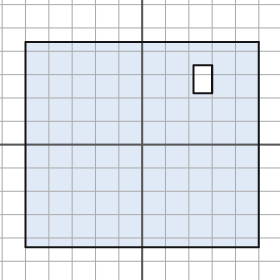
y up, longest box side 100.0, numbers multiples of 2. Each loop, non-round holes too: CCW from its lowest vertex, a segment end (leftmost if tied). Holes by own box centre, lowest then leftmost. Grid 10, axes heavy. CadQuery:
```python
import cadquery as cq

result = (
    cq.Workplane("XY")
    .moveTo(-50.0, -44.0)
    .lineTo(50.0, -44.0)
    .lineTo(50.0, 44.0)
    .lineTo(-50.0, 44.0)
    .close()
    .moveTo(22.0, 22.0)
    .lineTo(30.0, 22.0)
    .lineTo(30.0, 34.0)
    .lineTo(22.0, 34.0)
    .close()
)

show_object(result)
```